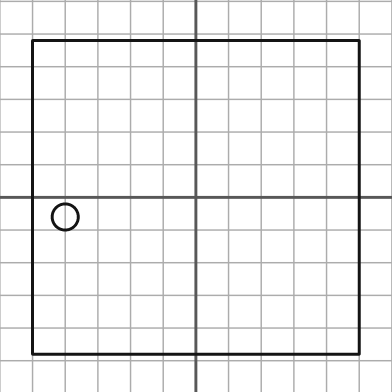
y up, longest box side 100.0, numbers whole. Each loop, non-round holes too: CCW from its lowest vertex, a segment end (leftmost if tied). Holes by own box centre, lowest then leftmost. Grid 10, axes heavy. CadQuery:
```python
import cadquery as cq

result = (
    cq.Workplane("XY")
    .moveTo(-50.0, -48.0)
    .lineTo(50.0, -48.0)
    .lineTo(50.0, 48.0)
    .lineTo(-50.0, 48.0)
    .close()
    .moveTo(-40.0, -6.0)
    .circle(4.0)
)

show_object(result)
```